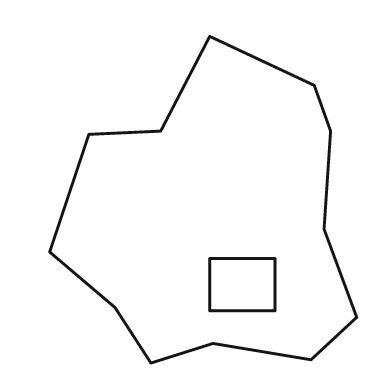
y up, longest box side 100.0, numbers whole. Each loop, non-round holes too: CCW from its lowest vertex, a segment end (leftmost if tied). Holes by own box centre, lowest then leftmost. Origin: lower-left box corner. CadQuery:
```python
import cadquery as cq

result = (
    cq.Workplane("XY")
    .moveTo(31.0, 0.0)
    .lineTo(50.0, 6.0)
    .lineTo(80.0, 1.0)
    .lineTo(94.0, 14.0)
    .lineTo(84.0, 41.0)
    .lineTo(86.0, 71.0)
    .lineTo(81.0, 85.0)
    .lineTo(49.0, 100.0)
    .lineTo(34.0, 71.0)
    .lineTo(12.0, 70.0)
    .lineTo(0.0, 34.0)
    .lineTo(20.0, 17.0)
    .close()
    .moveTo(49.0, 16.0)
    .lineTo(69.0, 16.0)
    .lineTo(69.0, 32.0)
    .lineTo(49.0, 32.0)
    .close()
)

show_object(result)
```